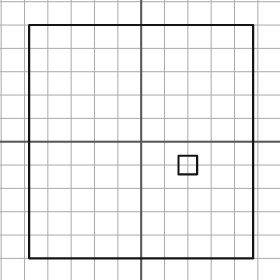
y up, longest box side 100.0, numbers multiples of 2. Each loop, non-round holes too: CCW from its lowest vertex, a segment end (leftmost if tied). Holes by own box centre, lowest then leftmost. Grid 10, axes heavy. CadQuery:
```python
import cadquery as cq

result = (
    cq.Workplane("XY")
    .moveTo(-48.0, -50.0)
    .lineTo(48.0, -50.0)
    .lineTo(48.0, 50.0)
    .lineTo(-48.0, 50.0)
    .close()
    .moveTo(16.0, -14.0)
    .lineTo(24.0, -14.0)
    .lineTo(24.0, -6.0)
    .lineTo(16.0, -6.0)
    .close()
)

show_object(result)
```